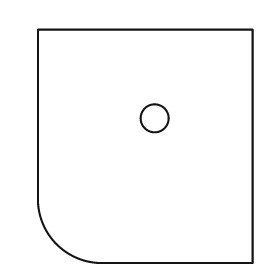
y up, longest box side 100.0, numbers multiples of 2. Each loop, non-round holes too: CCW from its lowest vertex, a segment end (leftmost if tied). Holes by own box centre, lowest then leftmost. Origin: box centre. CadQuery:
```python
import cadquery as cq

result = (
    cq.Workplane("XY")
    .moveTo(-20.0, -50.0)
    .lineTo(46.0, -50.0)
    .lineTo(46.0, 50.0)
    .lineTo(-46.0, 50.0)
    .lineTo(-46.0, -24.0)
    .threePointArc((-38.0, -42.0), (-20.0, -50.0))
    .close()
    .moveTo(4.0, 12.0)
    .circle(6.0)
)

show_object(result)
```